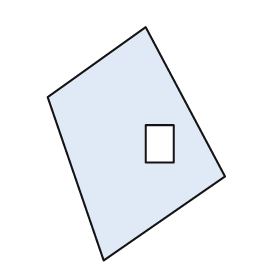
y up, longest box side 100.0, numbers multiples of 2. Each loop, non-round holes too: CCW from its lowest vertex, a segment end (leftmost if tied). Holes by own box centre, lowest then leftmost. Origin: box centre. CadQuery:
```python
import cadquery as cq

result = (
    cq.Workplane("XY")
    .moveTo(-14.0, -50.0)
    .lineTo(38.0, -14.0)
    .lineTo(4.0, 50.0)
    .lineTo(-38.0, 20.0)
    .close()
    .moveTo(4.0, -8.0)
    .lineTo(16.0, -8.0)
    .lineTo(16.0, 8.0)
    .lineTo(4.0, 8.0)
    .close()
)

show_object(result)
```